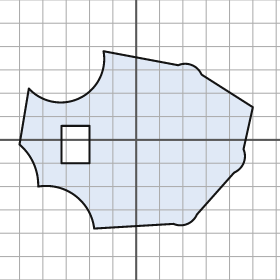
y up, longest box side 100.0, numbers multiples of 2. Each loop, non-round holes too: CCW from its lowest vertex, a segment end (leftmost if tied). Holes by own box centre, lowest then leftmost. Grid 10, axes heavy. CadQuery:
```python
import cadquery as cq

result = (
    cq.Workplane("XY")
    .moveTo(-18.0, -38.0)
    .lineTo(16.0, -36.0)
    .threePointArc((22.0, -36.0), (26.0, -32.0))
    .lineTo(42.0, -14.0)
    .threePointArc((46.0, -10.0), (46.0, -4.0))
    .lineTo(50.0, 14.0)
    .lineTo(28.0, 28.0)
    .threePointArc((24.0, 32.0), (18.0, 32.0))
    .lineTo(-14.0, 38.0)
    .threePointArc((-24.0, 18.0), (-46.0, 22.0))
    .lineTo(-50.0, -2.0)
    .threePointArc((-44.0, -10.0), (-42.0, -20.0))
    .threePointArc((-26.0, -24.0), (-18.0, -38.0))
    .close()
    .moveTo(-32.0, -10.0)
    .lineTo(-20.0, -10.0)
    .lineTo(-20.0, 6.0)
    .lineTo(-32.0, 6.0)
    .close()
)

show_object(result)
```